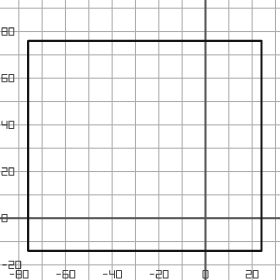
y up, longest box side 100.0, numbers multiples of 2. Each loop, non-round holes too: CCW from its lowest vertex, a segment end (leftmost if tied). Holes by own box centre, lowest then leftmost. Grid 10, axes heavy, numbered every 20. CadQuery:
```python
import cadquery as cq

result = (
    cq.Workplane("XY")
    .moveTo(-76.0, -14.0)
    .lineTo(24.0, -14.0)
    .lineTo(24.0, 76.0)
    .lineTo(-76.0, 76.0)
    .close()
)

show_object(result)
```